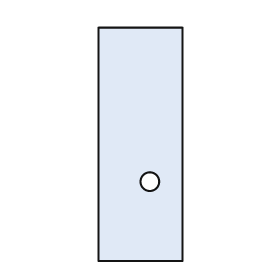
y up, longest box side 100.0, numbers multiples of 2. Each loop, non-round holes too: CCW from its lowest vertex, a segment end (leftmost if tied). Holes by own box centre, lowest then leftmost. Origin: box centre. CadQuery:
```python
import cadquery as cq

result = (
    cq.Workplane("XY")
    .moveTo(-18.0, -50.0)
    .lineTo(18.0, -50.0)
    .lineTo(18.0, 50.0)
    .lineTo(-18.0, 50.0)
    .close()
    .moveTo(4.0, -16.0)
    .circle(4.0)
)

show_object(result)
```